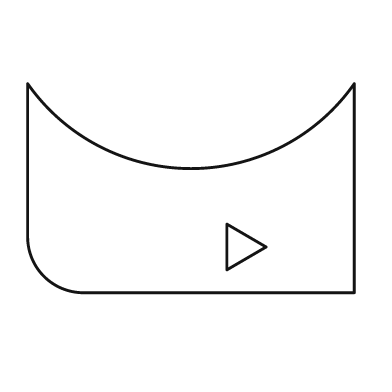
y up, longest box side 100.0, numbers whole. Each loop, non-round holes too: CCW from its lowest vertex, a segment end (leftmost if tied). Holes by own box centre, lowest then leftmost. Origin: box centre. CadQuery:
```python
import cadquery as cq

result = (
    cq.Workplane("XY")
    .moveTo(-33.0, -32.0)
    .lineTo(50.0, -32.0)
    .lineTo(50.0, 32.0)
    .threePointArc((0.0, 6.0), (-50.0, 32.0))
    .lineTo(-50.0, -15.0)
    .threePointArc((-45.0, -27.0), (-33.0, -32.0))
    .close()
    .moveTo(11.0, -25.0)
    .lineTo(23.0, -18.0)
    .lineTo(11.0, -11.0)
    .close()
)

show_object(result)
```